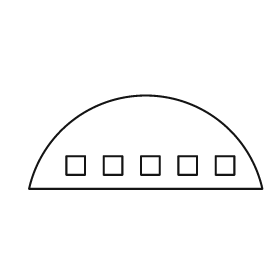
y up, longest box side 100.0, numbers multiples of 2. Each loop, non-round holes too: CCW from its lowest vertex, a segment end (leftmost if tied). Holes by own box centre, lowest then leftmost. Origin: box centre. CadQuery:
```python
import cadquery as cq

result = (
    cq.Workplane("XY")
    .moveTo(-50.0, -20.0)
    .lineTo(50.0, -20.0)
    .threePointArc((0.0, 20.0), (-50.0, -20.0))
    .close()
    .moveTo(-34.0, -14.0)
    .lineTo(-26.0, -14.0)
    .lineTo(-26.0, -6.0)
    .lineTo(-34.0, -6.0)
    .close()
    .moveTo(-18.0, -14.0)
    .lineTo(-10.0, -14.0)
    .lineTo(-10.0, -6.0)
    .lineTo(-18.0, -6.0)
    .close()
    .moveTo(-2.0, -14.0)
    .lineTo(6.0, -14.0)
    .lineTo(6.0, -6.0)
    .lineTo(-2.0, -6.0)
    .close()
    .moveTo(14.0, -14.0)
    .lineTo(22.0, -14.0)
    .lineTo(22.0, -6.0)
    .lineTo(14.0, -6.0)
    .close()
    .moveTo(30.0, -14.0)
    .lineTo(38.0, -14.0)
    .lineTo(38.0, -6.0)
    .lineTo(30.0, -6.0)
    .close()
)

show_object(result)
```